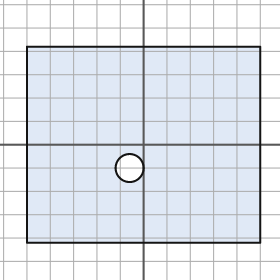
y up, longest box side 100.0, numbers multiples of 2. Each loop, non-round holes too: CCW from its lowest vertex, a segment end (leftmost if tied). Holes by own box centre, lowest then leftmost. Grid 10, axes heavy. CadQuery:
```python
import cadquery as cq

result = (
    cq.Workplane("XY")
    .moveTo(-50.0, -42.0)
    .lineTo(50.0, -42.0)
    .lineTo(50.0, 42.0)
    .lineTo(-50.0, 42.0)
    .close()
    .moveTo(-6.0, -10.0)
    .circle(6.0)
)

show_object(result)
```